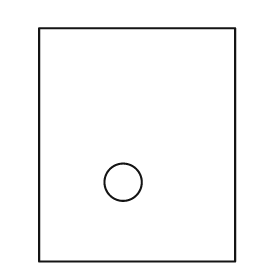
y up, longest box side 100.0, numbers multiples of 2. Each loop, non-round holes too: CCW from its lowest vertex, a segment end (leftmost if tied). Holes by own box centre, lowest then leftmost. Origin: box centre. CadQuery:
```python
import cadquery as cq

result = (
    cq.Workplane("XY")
    .moveTo(-42.0, -50.0)
    .lineTo(42.0, -50.0)
    .lineTo(42.0, 50.0)
    .lineTo(-42.0, 50.0)
    .close()
    .moveTo(-6.0, -16.0)
    .circle(8.0)
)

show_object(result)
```